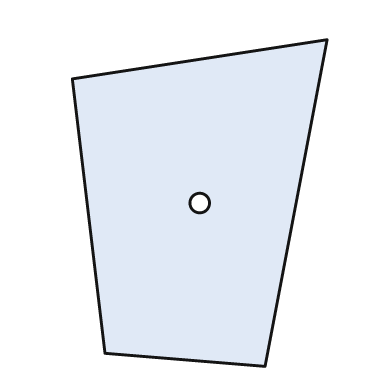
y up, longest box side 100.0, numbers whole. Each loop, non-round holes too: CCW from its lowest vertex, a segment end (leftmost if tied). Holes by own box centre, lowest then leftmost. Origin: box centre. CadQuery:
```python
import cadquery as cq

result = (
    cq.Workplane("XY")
    .moveTo(20.0, -50.0)
    .lineTo(39.0, 50.0)
    .lineTo(-39.0, 38.0)
    .lineTo(-29.0, -46.0)
    .close()
    .moveTo(0.0, 0.0)
    .circle(3.0)
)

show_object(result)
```